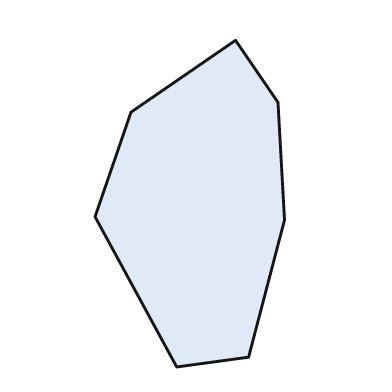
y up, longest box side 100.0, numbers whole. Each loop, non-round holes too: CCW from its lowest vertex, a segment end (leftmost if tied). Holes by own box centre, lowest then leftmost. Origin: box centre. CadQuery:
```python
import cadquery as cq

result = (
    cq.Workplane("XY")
    .moveTo(-4.0, -50.0)
    .lineTo(18.0, -47.0)
    .lineTo(29.0, -5.0)
    .lineTo(27.0, 31.0)
    .lineTo(14.0, 50.0)
    .lineTo(-18.0, 28.0)
    .lineTo(-29.0, -4.0)
    .close()
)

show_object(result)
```